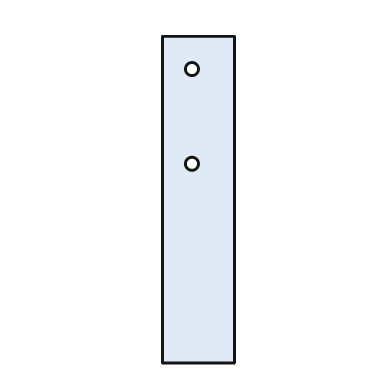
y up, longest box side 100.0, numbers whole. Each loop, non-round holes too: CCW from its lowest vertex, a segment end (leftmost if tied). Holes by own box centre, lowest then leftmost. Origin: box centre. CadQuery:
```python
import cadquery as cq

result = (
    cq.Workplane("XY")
    .moveTo(-11.0, -50.0)
    .lineTo(11.0, -50.0)
    .lineTo(11.0, 50.0)
    .lineTo(-11.0, 50.0)
    .close()
    .moveTo(-2.0, 11.0)
    .circle(2.0)
    .moveTo(-2.0, 40.0)
    .circle(2.0)
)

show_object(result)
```